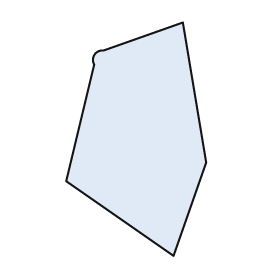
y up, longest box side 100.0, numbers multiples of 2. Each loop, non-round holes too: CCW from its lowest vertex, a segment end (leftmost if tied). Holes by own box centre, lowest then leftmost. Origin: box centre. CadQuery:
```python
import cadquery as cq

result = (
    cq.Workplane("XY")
    .moveTo(16.0, -50.0)
    .lineTo(30.0, -10.0)
    .lineTo(20.0, 50.0)
    .lineTo(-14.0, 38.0)
    .threePointArc((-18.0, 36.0), (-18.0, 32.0))
    .lineTo(-30.0, -18.0)
    .close()
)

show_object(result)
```